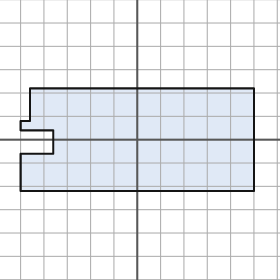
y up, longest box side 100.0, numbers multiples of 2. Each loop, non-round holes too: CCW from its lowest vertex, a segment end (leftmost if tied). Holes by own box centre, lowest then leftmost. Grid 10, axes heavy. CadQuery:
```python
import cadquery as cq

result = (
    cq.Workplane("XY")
    .moveTo(-50.0, -22.0)
    .lineTo(50.0, -22.0)
    .lineTo(50.0, 22.0)
    .lineTo(-46.0, 22.0)
    .lineTo(-46.0, 8.0)
    .lineTo(-50.0, 8.0)
    .lineTo(-50.0, 4.0)
    .lineTo(-36.0, 4.0)
    .lineTo(-36.0, -6.0)
    .lineTo(-50.0, -6.0)
    .close()
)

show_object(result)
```